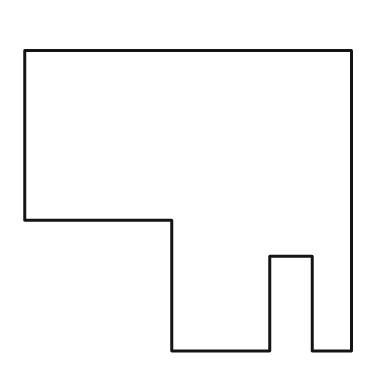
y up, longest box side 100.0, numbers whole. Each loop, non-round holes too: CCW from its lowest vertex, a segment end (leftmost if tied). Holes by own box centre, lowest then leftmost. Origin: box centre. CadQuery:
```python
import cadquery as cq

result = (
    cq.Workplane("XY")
    .moveTo(-5.0, -46.0)
    .lineTo(25.0, -46.0)
    .lineTo(25.0, -17.0)
    .lineTo(38.0, -17.0)
    .lineTo(38.0, -46.0)
    .lineTo(50.0, -46.0)
    .lineTo(50.0, 46.0)
    .lineTo(-50.0, 46.0)
    .lineTo(-50.0, -6.0)
    .lineTo(-5.0, -6.0)
    .close()
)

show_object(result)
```